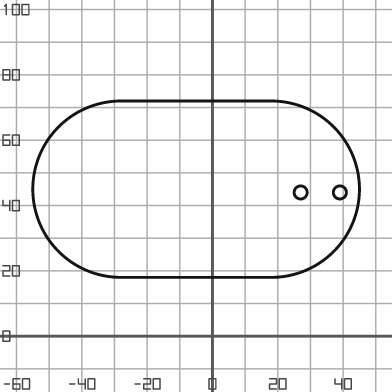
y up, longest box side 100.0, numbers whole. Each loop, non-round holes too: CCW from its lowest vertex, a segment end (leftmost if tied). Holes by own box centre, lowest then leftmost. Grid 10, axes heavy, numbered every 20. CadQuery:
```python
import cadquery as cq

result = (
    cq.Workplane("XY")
    .moveTo(-28.0, 18.0)
    .lineTo(18.0, 18.0)
    .threePointArc((45.0, 45.0), (18.0, 72.0))
    .lineTo(-28.0, 72.0)
    .threePointArc((-55.0, 45.0), (-28.0, 18.0))
    .close()
    .moveTo(27.0, 44.0)
    .circle(2.0)
    .moveTo(39.0, 44.0)
    .circle(2.0)
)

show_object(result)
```